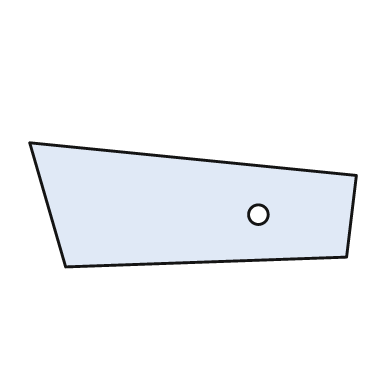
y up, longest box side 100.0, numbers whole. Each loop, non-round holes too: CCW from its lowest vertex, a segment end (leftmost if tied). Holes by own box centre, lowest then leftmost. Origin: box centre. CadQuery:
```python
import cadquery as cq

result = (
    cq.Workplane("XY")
    .moveTo(-39.0, -19.0)
    .lineTo(47.0, -16.0)
    .lineTo(50.0, 9.0)
    .lineTo(-50.0, 19.0)
    .close()
    .moveTo(20.0, -3.0)
    .circle(3.0)
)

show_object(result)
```